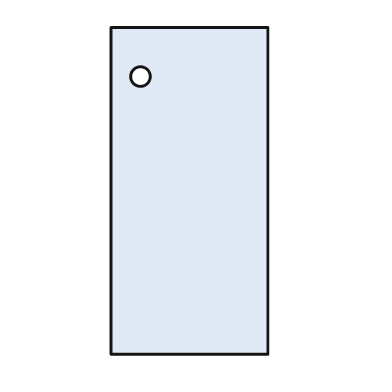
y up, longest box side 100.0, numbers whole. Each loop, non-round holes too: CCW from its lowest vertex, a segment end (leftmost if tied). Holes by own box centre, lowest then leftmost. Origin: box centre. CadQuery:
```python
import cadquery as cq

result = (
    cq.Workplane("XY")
    .moveTo(-24.0, -50.0)
    .lineTo(24.0, -50.0)
    .lineTo(24.0, 50.0)
    .lineTo(-24.0, 50.0)
    .close()
    .moveTo(-15.0, 35.0)
    .circle(3.0)
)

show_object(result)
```